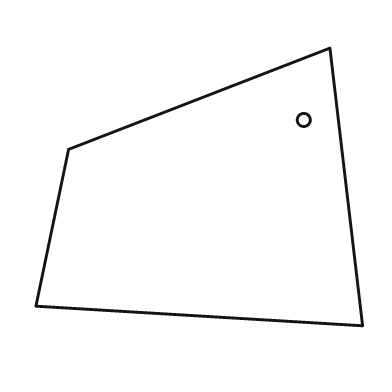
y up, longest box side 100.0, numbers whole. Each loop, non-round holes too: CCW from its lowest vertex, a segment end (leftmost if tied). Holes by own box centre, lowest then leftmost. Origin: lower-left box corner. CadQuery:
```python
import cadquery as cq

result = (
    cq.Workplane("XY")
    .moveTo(100.0, 0.0)
    .lineTo(90.0, 85.0)
    .lineTo(10.0, 54.0)
    .lineTo(0.0, 6.0)
    .close()
    .moveTo(82.0, 63.0)
    .circle(2.0)
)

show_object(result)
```